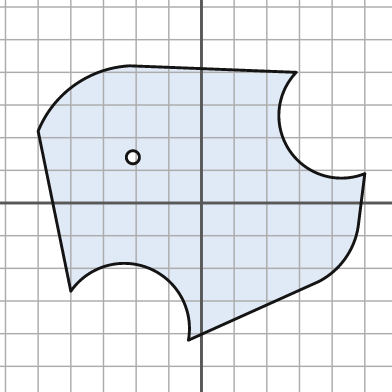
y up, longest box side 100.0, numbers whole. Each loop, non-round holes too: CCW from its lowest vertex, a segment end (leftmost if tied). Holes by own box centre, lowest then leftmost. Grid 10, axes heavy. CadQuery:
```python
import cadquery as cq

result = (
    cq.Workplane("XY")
    .moveTo(-4.0, -42.0)
    .lineTo(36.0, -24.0)
    .threePointArc((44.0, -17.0), (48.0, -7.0))
    .lineTo(50.0, 9.0)
    .threePointArc((27.0, 16.0), (29.0, 40.0))
    .lineTo(-22.0, 42.0)
    .threePointArc((-39.0, 36.0), (-50.0, 22.0))
    .lineTo(-40.0, -27.0)
    .threePointArc((-16.0, -20.0), (-4.0, -42.0))
    .close()
    .moveTo(-21.0, 14.0)
    .circle(2.0)
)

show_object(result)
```